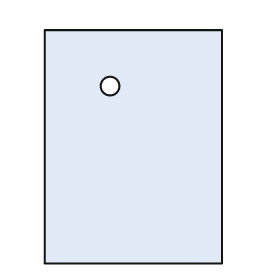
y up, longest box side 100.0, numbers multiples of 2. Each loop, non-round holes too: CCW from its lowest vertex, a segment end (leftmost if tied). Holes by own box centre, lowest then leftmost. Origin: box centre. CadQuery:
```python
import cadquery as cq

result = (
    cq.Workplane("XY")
    .moveTo(-38.0, -50.0)
    .lineTo(38.0, -50.0)
    .lineTo(38.0, 50.0)
    .lineTo(-38.0, 50.0)
    .close()
    .moveTo(-10.0, 26.0)
    .circle(4.0)
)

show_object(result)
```